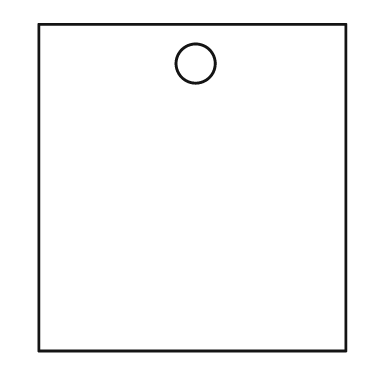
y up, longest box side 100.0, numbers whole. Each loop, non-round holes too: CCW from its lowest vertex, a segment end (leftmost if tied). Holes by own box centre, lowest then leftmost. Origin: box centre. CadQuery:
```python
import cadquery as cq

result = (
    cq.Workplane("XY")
    .moveTo(-47.0, -50.0)
    .lineTo(47.0, -50.0)
    .lineTo(47.0, 50.0)
    .lineTo(-47.0, 50.0)
    .close()
    .moveTo(1.0, 38.0)
    .circle(6.0)
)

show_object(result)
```